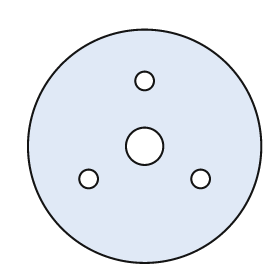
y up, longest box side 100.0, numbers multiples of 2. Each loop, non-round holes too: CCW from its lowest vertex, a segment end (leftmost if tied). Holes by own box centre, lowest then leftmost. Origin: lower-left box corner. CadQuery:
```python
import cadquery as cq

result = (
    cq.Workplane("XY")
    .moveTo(50.0, 50.0)
    .circle(50.0)
    .moveTo(26.0, 36.0)
    .circle(4.0)
    .moveTo(74.0, 36.0)
    .circle(4.0)
    .moveTo(50.0, 50.0)
    .circle(8.0)
    .moveTo(50.0, 78.0)
    .circle(4.0)
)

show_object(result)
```